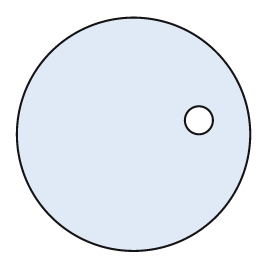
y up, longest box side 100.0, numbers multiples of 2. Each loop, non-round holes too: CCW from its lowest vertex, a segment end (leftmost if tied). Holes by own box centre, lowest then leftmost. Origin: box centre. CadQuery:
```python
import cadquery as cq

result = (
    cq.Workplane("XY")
    .moveTo(0.0, 0.0)
    .circle(50.0)
    .moveTo(28.0, 6.0)
    .circle(6.0)
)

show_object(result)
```